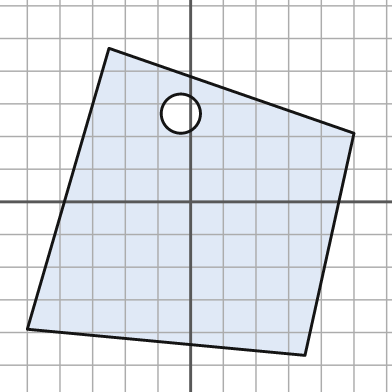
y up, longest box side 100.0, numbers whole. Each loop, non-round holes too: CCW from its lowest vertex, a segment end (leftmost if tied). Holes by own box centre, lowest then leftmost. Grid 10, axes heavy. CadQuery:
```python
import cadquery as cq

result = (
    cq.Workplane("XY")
    .moveTo(35.0, -47.0)
    .lineTo(50.0, 21.0)
    .lineTo(-25.0, 47.0)
    .lineTo(-50.0, -39.0)
    .close()
    .moveTo(-3.0, 27.0)
    .circle(6.0)
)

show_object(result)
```